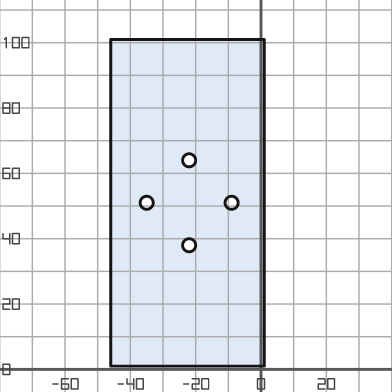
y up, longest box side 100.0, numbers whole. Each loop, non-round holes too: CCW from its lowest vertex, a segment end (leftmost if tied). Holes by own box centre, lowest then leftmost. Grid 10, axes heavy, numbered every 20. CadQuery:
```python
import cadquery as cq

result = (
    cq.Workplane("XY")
    .moveTo(-46.0, 1.0)
    .lineTo(1.0, 1.0)
    .lineTo(1.0, 101.0)
    .lineTo(-46.0, 101.0)
    .close()
    .moveTo(-22.0, 38.0)
    .circle(2.0)
    .moveTo(-35.0, 51.0)
    .circle(2.0)
    .moveTo(-9.0, 51.0)
    .circle(2.0)
    .moveTo(-22.0, 64.0)
    .circle(2.0)
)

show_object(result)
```